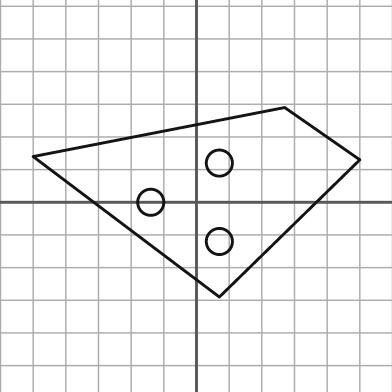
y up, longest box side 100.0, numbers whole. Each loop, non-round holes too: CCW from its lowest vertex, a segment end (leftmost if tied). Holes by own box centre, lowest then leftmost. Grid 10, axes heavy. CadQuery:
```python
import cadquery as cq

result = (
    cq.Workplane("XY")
    .moveTo(7.0, -29.0)
    .lineTo(50.0, 13.0)
    .lineTo(27.0, 29.0)
    .lineTo(-50.0, 14.0)
    .close()
    .moveTo(7.0, -12.0)
    .circle(4.0)
    .moveTo(-14.0, 0.0)
    .circle(4.0)
    .moveTo(7.0, 12.0)
    .circle(4.0)
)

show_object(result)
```